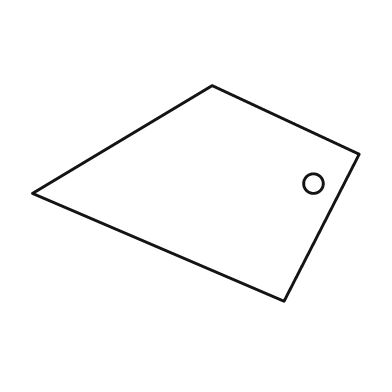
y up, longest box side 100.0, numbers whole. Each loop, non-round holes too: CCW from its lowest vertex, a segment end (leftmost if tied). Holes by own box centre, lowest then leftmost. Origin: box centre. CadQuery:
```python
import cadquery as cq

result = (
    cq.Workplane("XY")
    .moveTo(27.0, -33.0)
    .lineTo(50.0, 12.0)
    .lineTo(5.0, 33.0)
    .lineTo(-50.0, 0.0)
    .close()
    .moveTo(36.0, 3.0)
    .circle(3.0)
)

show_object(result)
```